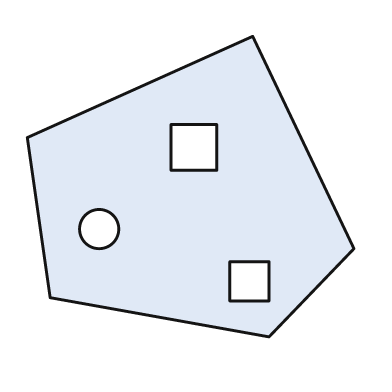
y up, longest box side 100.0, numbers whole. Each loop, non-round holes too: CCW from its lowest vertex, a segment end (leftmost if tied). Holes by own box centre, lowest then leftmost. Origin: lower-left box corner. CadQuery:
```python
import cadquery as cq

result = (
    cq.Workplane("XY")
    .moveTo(74.0, 0.0)
    .lineTo(100.0, 27.0)
    .lineTo(69.0, 92.0)
    .lineTo(0.0, 61.0)
    .lineTo(7.0, 12.0)
    .close()
    .moveTo(62.0, 11.0)
    .lineTo(74.0, 11.0)
    .lineTo(74.0, 23.0)
    .lineTo(62.0, 23.0)
    .close()
    .moveTo(22.0, 33.0)
    .circle(6.0)
    .moveTo(44.0, 51.0)
    .lineTo(58.0, 51.0)
    .lineTo(58.0, 65.0)
    .lineTo(44.0, 65.0)
    .close()
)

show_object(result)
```